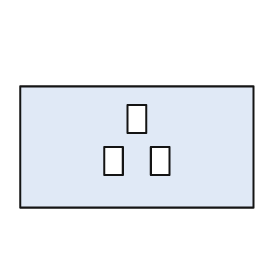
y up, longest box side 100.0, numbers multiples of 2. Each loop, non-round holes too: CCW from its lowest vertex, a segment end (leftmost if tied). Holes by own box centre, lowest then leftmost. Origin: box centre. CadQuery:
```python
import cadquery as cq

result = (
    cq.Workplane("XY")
    .moveTo(-50.0, -26.0)
    .lineTo(50.0, -26.0)
    .lineTo(50.0, 26.0)
    .lineTo(-50.0, 26.0)
    .close()
    .moveTo(-14.0, -12.0)
    .lineTo(-6.0, -12.0)
    .lineTo(-6.0, 0.0)
    .lineTo(-14.0, 0.0)
    .close()
    .moveTo(6.0, -12.0)
    .lineTo(14.0, -12.0)
    .lineTo(14.0, 0.0)
    .lineTo(6.0, 0.0)
    .close()
    .moveTo(-4.0, 6.0)
    .lineTo(4.0, 6.0)
    .lineTo(4.0, 18.0)
    .lineTo(-4.0, 18.0)
    .close()
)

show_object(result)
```